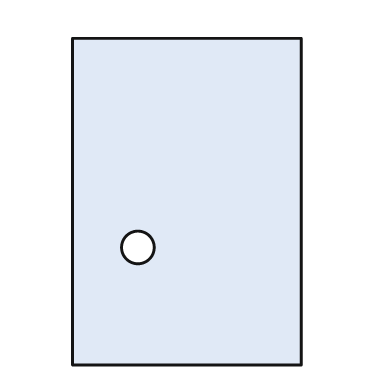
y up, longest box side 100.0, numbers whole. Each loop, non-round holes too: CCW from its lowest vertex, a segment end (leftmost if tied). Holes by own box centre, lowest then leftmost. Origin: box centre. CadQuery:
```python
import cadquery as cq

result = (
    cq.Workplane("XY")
    .moveTo(-35.0, -50.0)
    .lineTo(35.0, -50.0)
    .lineTo(35.0, 50.0)
    .lineTo(-35.0, 50.0)
    .close()
    .moveTo(-15.0, -14.0)
    .circle(5.0)
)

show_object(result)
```